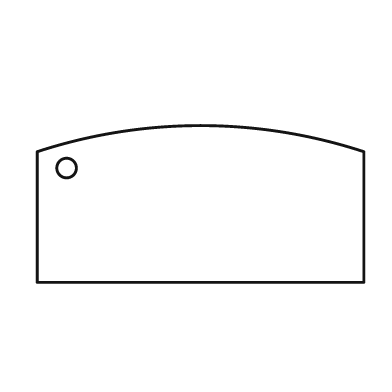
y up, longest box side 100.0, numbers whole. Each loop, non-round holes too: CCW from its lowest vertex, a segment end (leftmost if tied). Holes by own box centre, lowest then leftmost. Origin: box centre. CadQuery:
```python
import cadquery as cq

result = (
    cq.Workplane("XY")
    .moveTo(-50.0, -24.0)
    .lineTo(50.0, -24.0)
    .lineTo(50.0, 16.0)
    .threePointArc((0.0, 24.0), (-50.0, 16.0))
    .close()
    .moveTo(-41.0, 11.0)
    .circle(3.0)
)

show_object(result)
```